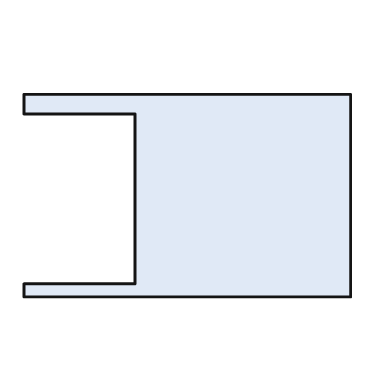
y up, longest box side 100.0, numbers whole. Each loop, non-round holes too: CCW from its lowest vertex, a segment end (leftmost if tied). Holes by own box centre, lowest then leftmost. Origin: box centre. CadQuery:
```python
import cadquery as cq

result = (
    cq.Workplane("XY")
    .moveTo(-50.0, -31.0)
    .lineTo(50.0, -31.0)
    .lineTo(50.0, 31.0)
    .lineTo(-50.0, 31.0)
    .lineTo(-50.0, 25.0)
    .lineTo(-16.0, 25.0)
    .lineTo(-16.0, -27.0)
    .lineTo(-50.0, -27.0)
    .close()
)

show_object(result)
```